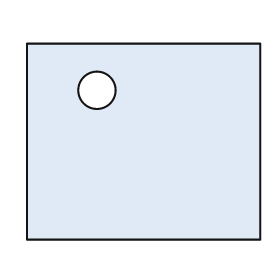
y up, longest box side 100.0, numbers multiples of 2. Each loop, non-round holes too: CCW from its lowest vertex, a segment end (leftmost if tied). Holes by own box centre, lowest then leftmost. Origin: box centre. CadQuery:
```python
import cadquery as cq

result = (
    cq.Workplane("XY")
    .moveTo(-50.0, -42.0)
    .lineTo(50.0, -42.0)
    .lineTo(50.0, 42.0)
    .lineTo(-50.0, 42.0)
    .close()
    .moveTo(-20.0, 22.0)
    .circle(8.0)
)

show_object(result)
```